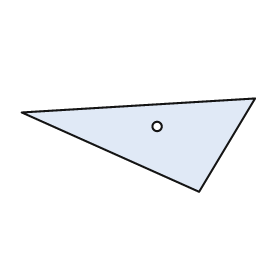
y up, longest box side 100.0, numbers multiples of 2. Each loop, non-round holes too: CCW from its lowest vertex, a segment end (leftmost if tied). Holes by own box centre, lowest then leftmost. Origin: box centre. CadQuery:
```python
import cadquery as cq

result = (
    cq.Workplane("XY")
    .moveTo(26.0, -20.0)
    .lineTo(50.0, 20.0)
    .lineTo(-50.0, 14.0)
    .close()
    .moveTo(8.0, 8.0)
    .circle(2.0)
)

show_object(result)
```